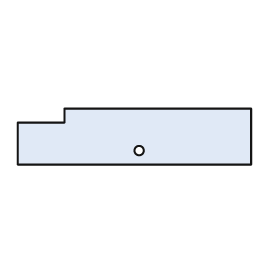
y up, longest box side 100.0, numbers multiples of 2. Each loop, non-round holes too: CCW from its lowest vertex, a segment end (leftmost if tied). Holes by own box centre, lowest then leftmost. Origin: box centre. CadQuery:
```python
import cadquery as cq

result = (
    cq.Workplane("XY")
    .moveTo(-50.0, -12.0)
    .lineTo(50.0, -12.0)
    .lineTo(50.0, 12.0)
    .lineTo(-30.0, 12.0)
    .lineTo(-30.0, 6.0)
    .lineTo(-50.0, 6.0)
    .close()
    .moveTo(2.0, -6.0)
    .circle(2.0)
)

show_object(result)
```